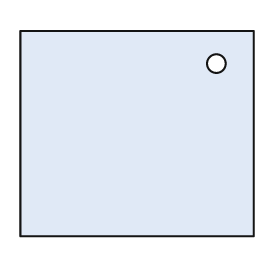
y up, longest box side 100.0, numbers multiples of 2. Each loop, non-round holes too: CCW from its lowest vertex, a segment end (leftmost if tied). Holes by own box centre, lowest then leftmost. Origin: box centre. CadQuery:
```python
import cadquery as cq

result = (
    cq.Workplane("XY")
    .moveTo(-50.0, -44.0)
    .lineTo(50.0, -44.0)
    .lineTo(50.0, 44.0)
    .lineTo(-50.0, 44.0)
    .close()
    .moveTo(34.0, 30.0)
    .circle(4.0)
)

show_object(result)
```